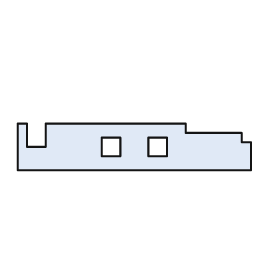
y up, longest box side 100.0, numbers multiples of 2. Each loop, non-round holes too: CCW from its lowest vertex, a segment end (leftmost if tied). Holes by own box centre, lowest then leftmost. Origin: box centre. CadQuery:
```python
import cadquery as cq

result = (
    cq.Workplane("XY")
    .moveTo(-50.0, -10.0)
    .lineTo(50.0, -10.0)
    .lineTo(50.0, 2.0)
    .lineTo(46.0, 2.0)
    .lineTo(46.0, 6.0)
    .lineTo(22.0, 6.0)
    .lineTo(22.0, 10.0)
    .lineTo(-38.0, 10.0)
    .lineTo(-38.0, 0.0)
    .lineTo(-46.0, 0.0)
    .lineTo(-46.0, 10.0)
    .lineTo(-50.0, 10.0)
    .close()
    .moveTo(-14.0, -4.0)
    .lineTo(-6.0, -4.0)
    .lineTo(-6.0, 4.0)
    .lineTo(-14.0, 4.0)
    .close()
    .moveTo(6.0, -4.0)
    .lineTo(14.0, -4.0)
    .lineTo(14.0, 4.0)
    .lineTo(6.0, 4.0)
    .close()
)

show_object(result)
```